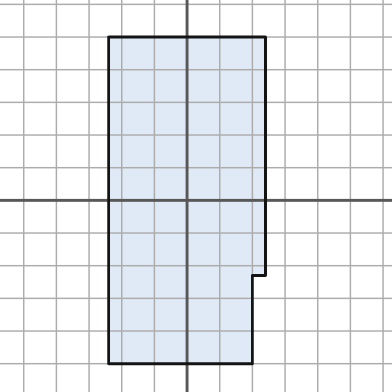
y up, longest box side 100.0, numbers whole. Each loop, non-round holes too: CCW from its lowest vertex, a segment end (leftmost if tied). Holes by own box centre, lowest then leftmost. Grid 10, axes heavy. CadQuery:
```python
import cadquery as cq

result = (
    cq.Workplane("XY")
    .moveTo(-24.0, -50.0)
    .lineTo(20.0, -50.0)
    .lineTo(20.0, -23.0)
    .lineTo(24.0, -23.0)
    .lineTo(24.0, 50.0)
    .lineTo(-24.0, 50.0)
    .close()
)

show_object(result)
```